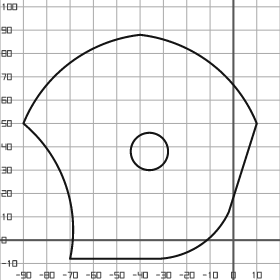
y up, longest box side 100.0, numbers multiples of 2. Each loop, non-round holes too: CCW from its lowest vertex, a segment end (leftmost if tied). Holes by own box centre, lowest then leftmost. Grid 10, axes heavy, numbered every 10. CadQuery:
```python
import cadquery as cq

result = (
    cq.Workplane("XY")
    .moveTo(-70.0, -8.0)
    .lineTo(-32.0, -8.0)
    .threePointArc((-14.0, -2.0), (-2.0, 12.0))
    .lineTo(10.0, 50.0)
    .threePointArc((-10.0, 76.0), (-40.0, 88.0))
    .threePointArc((-70.0, 76.0), (-90.0, 50.0))
    .threePointArc((-72.0, 24.0), (-70.0, -8.0))
    .close()
    .moveTo(-36.0, 38.0)
    .circle(8.0)
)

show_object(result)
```